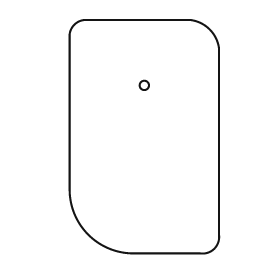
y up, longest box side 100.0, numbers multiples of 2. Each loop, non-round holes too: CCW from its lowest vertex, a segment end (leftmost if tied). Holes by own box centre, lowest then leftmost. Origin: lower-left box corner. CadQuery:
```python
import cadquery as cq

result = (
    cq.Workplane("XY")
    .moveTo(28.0, 0.0)
    .lineTo(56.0, 0.0)
    .threePointArc((62.0, 2.0), (64.0, 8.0))
    .lineTo(64.0, 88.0)
    .threePointArc((60.0, 96.0), (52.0, 100.0))
    .lineTo(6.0, 100.0)
    .threePointArc((2.0, 98.0), (0.0, 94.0))
    .lineTo(0.0, 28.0)
    .threePointArc((8.0, 8.0), (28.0, 0.0))
    .close()
    .moveTo(32.0, 72.0)
    .circle(2.0)
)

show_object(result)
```